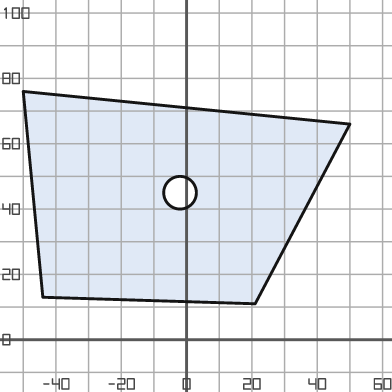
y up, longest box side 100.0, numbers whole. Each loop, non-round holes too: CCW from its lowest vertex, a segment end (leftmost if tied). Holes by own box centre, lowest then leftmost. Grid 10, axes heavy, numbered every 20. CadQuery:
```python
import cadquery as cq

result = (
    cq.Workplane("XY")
    .moveTo(21.0, 11.0)
    .lineTo(50.0, 66.0)
    .lineTo(-50.0, 76.0)
    .lineTo(-44.0, 13.0)
    .close()
    .moveTo(-2.0, 45.0)
    .circle(5.0)
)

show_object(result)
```